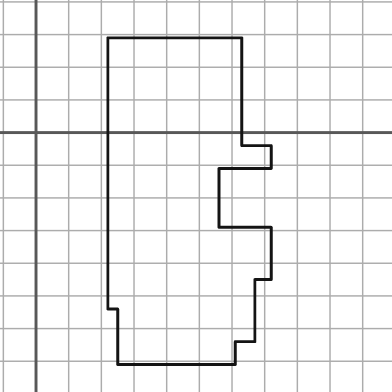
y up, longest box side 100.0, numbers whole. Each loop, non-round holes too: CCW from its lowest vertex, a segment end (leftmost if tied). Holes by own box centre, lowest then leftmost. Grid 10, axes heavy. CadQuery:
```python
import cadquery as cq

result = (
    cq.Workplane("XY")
    .moveTo(25.0, -71.0)
    .lineTo(61.0, -71.0)
    .lineTo(61.0, -64.0)
    .lineTo(67.0, -64.0)
    .lineTo(67.0, -45.0)
    .lineTo(72.0, -45.0)
    .lineTo(72.0, -29.0)
    .lineTo(56.0, -29.0)
    .lineTo(56.0, -11.0)
    .lineTo(72.0, -11.0)
    .lineTo(72.0, -4.0)
    .lineTo(63.0, -4.0)
    .lineTo(63.0, 29.0)
    .lineTo(22.0, 29.0)
    .lineTo(22.0, -54.0)
    .lineTo(25.0, -54.0)
    .close()
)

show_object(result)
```